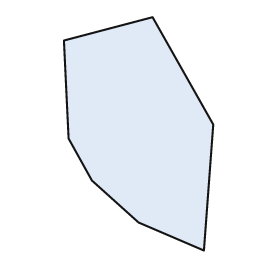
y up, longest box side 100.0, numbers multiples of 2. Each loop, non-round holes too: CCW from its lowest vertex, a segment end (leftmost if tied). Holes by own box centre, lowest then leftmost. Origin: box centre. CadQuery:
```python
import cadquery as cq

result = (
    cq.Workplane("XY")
    .moveTo(28.0, -50.0)
    .lineTo(32.0, 4.0)
    .lineTo(6.0, 50.0)
    .lineTo(-32.0, 40.0)
    .lineTo(-30.0, -2.0)
    .lineTo(-20.0, -20.0)
    .lineTo(0.0, -38.0)
    .close()
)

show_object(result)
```